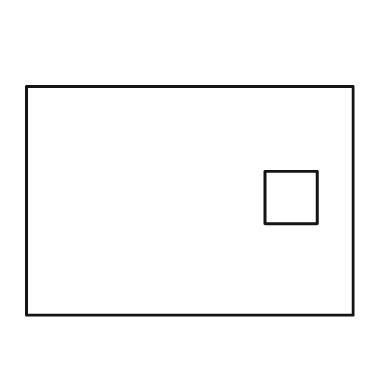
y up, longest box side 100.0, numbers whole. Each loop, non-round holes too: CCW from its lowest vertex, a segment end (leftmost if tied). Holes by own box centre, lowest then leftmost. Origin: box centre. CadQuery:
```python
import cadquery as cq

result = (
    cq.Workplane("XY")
    .moveTo(-50.0, -35.0)
    .lineTo(50.0, -35.0)
    .lineTo(50.0, 35.0)
    .lineTo(-50.0, 35.0)
    .close()
    .moveTo(23.0, -7.0)
    .lineTo(39.0, -7.0)
    .lineTo(39.0, 9.0)
    .lineTo(23.0, 9.0)
    .close()
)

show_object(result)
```